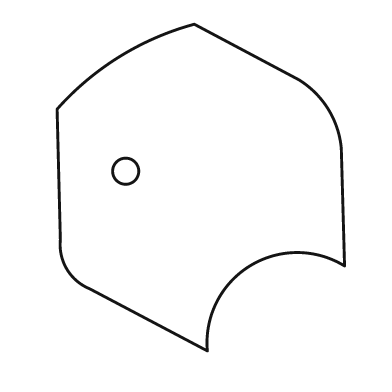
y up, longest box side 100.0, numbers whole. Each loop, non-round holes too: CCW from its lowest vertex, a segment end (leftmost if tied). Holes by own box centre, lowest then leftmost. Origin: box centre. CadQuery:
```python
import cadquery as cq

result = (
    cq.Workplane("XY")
    .moveTo(2.0, -50.0)
    .threePointArc((15.0, -24.0), (44.0, -24.0))
    .lineTo(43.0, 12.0)
    .threePointArc((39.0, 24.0), (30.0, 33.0))
    .lineTo(-2.0, 50.0)
    .threePointArc((-25.0, 40.0), (-44.0, 24.0))
    .lineTo(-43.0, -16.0)
    .threePointArc((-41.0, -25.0), (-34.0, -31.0))
    .close()
    .moveTo(-23.0, 5.0)
    .circle(4.0)
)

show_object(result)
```